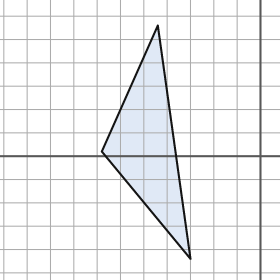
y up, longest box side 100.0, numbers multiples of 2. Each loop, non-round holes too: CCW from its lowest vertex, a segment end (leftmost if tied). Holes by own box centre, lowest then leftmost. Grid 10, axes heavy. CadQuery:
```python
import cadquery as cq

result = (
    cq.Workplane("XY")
    .moveTo(-30.0, -44.0)
    .lineTo(-44.0, 56.0)
    .lineTo(-68.0, 2.0)
    .close()
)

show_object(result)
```